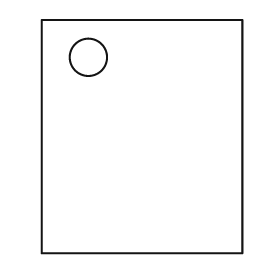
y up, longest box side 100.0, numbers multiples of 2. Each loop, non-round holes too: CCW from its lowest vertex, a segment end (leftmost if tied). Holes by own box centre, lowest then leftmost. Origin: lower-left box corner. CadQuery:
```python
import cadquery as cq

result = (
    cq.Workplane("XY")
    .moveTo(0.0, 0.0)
    .lineTo(86.0, 0.0)
    .lineTo(86.0, 100.0)
    .lineTo(0.0, 100.0)
    .close()
    .moveTo(20.0, 84.0)
    .circle(8.0)
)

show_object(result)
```